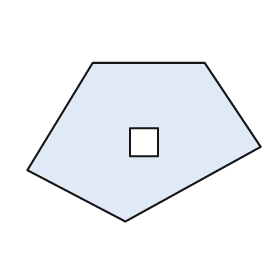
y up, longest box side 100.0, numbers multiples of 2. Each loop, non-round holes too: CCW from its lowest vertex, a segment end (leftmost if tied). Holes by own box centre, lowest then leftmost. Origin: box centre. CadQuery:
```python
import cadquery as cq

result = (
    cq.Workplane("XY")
    .moveTo(-8.0, -34.0)
    .lineTo(50.0, -2.0)
    .lineTo(26.0, 34.0)
    .lineTo(-22.0, 34.0)
    .lineTo(-50.0, -12.0)
    .close()
    .moveTo(-6.0, -6.0)
    .lineTo(6.0, -6.0)
    .lineTo(6.0, 6.0)
    .lineTo(-6.0, 6.0)
    .close()
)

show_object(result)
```